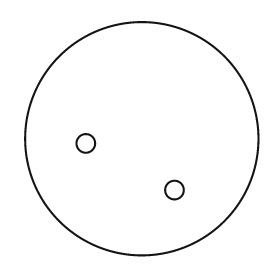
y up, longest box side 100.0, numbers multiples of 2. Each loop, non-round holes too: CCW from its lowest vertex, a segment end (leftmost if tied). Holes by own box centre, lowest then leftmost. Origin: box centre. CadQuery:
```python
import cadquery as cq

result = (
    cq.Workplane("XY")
    .moveTo(0.0, 0.0)
    .circle(50.0)
    .moveTo(14.0, -22.0)
    .circle(4.0)
    .moveTo(-24.0, -2.0)
    .circle(4.0)
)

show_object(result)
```